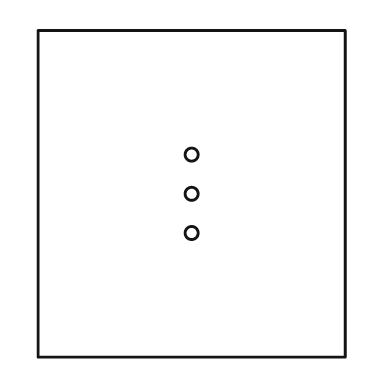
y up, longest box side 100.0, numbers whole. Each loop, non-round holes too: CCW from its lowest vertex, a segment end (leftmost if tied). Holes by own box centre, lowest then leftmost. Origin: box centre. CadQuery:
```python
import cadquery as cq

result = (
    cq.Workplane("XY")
    .moveTo(-47.0, -50.0)
    .lineTo(47.0, -50.0)
    .lineTo(47.0, 50.0)
    .lineTo(-47.0, 50.0)
    .close()
    .moveTo(0.0, -12.0)
    .circle(2.0)
    .moveTo(0.0, 0.0)
    .circle(2.0)
    .moveTo(0.0, 12.0)
    .circle(2.0)
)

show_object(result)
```